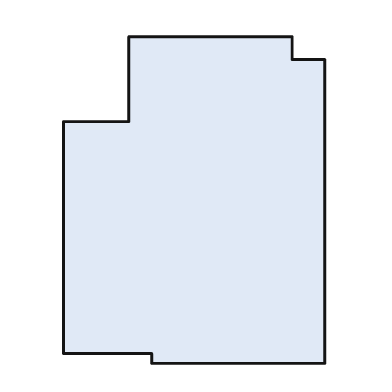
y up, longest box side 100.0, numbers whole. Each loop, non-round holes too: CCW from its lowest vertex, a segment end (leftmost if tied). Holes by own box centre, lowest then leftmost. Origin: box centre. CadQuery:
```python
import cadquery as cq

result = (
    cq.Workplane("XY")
    .moveTo(-13.0, -50.0)
    .lineTo(40.0, -50.0)
    .lineTo(40.0, 43.0)
    .lineTo(30.0, 43.0)
    .lineTo(30.0, 50.0)
    .lineTo(-20.0, 50.0)
    .lineTo(-20.0, 24.0)
    .lineTo(-40.0, 24.0)
    .lineTo(-40.0, -47.0)
    .lineTo(-13.0, -47.0)
    .close()
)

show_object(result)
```